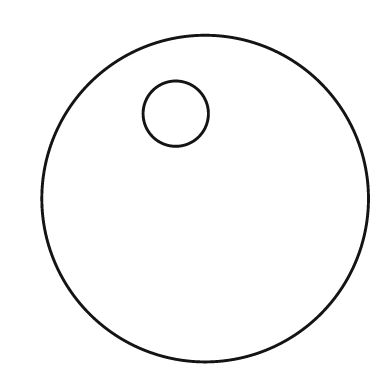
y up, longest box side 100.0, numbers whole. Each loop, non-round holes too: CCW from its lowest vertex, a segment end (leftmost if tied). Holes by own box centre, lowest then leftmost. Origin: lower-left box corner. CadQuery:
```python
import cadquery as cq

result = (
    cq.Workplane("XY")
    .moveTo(50.0, 50.0)
    .circle(50.0)
    .moveTo(41.0, 76.0)
    .circle(10.0)
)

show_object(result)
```